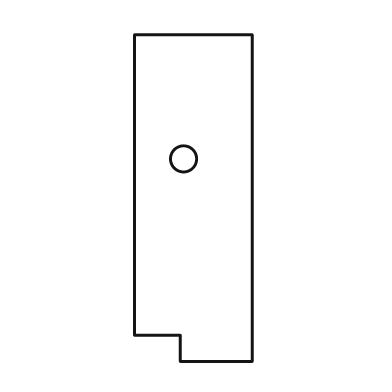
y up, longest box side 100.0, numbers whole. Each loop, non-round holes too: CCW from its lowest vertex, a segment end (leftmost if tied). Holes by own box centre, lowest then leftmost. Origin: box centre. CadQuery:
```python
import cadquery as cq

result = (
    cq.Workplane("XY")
    .moveTo(-4.0, -50.0)
    .lineTo(18.0, -50.0)
    .lineTo(18.0, 50.0)
    .lineTo(-18.0, 50.0)
    .lineTo(-18.0, -42.0)
    .lineTo(-4.0, -42.0)
    .close()
    .moveTo(-3.0, 12.0)
    .circle(4.0)
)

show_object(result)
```